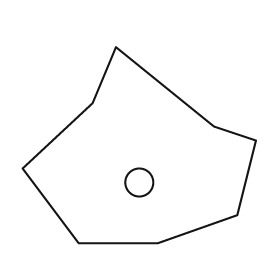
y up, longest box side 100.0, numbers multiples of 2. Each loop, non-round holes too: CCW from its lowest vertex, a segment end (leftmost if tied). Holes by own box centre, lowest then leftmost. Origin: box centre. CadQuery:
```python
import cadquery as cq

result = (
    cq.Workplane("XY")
    .moveTo(-26.0, -42.0)
    .lineTo(8.0, -42.0)
    .lineTo(42.0, -30.0)
    .lineTo(50.0, 2.0)
    .lineTo(32.0, 8.0)
    .lineTo(-10.0, 42.0)
    .lineTo(-20.0, 18.0)
    .lineTo(-50.0, -10.0)
    .close()
    .moveTo(0.0, -16.0)
    .circle(6.0)
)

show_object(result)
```